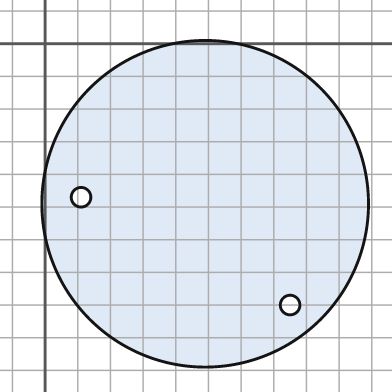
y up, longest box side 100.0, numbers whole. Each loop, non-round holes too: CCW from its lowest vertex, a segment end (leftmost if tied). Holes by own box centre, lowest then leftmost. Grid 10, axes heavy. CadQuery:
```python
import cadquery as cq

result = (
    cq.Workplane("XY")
    .moveTo(49.0, -49.0)
    .circle(50.0)
    .moveTo(75.0, -80.0)
    .circle(3.0)
    .moveTo(11.0, -47.0)
    .circle(3.0)
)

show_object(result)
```